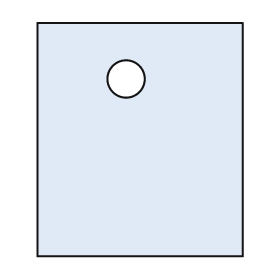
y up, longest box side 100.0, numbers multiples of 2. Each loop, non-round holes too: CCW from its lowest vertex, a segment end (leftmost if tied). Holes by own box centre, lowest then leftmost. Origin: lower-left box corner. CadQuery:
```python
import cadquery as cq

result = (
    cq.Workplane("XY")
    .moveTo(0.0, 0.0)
    .lineTo(88.0, 0.0)
    .lineTo(88.0, 100.0)
    .lineTo(0.0, 100.0)
    .close()
    .moveTo(38.0, 76.0)
    .circle(8.0)
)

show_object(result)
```